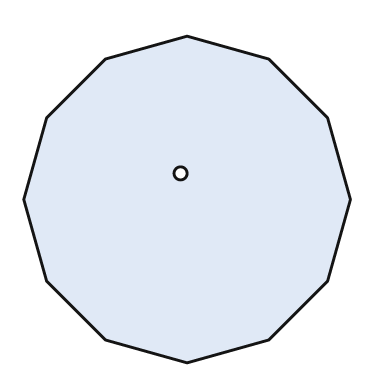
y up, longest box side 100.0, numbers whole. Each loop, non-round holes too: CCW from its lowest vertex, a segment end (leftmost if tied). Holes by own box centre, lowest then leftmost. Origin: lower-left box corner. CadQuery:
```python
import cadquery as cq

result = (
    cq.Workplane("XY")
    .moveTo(50.0, 0.0)
    .lineTo(75.0, 7.0)
    .lineTo(93.0, 25.0)
    .lineTo(100.0, 50.0)
    .lineTo(93.0, 75.0)
    .lineTo(75.0, 93.0)
    .lineTo(50.0, 100.0)
    .lineTo(25.0, 93.0)
    .lineTo(7.0, 75.0)
    .lineTo(0.0, 50.0)
    .lineTo(7.0, 25.0)
    .lineTo(25.0, 7.0)
    .close()
    .moveTo(48.0, 58.0)
    .circle(2.0)
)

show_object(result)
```